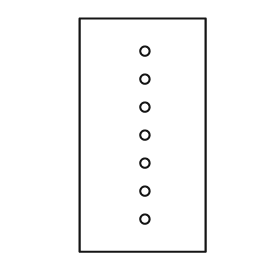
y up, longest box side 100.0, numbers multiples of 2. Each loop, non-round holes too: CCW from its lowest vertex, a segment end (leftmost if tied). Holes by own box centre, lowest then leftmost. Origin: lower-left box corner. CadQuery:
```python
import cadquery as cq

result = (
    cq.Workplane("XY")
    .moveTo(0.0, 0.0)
    .lineTo(54.0, 0.0)
    .lineTo(54.0, 100.0)
    .lineTo(0.0, 100.0)
    .close()
    .moveTo(28.0, 14.0)
    .circle(2.0)
    .moveTo(28.0, 26.0)
    .circle(2.0)
    .moveTo(28.0, 38.0)
    .circle(2.0)
    .moveTo(28.0, 50.0)
    .circle(2.0)
    .moveTo(28.0, 62.0)
    .circle(2.0)
    .moveTo(28.0, 74.0)
    .circle(2.0)
    .moveTo(28.0, 86.0)
    .circle(2.0)
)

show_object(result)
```